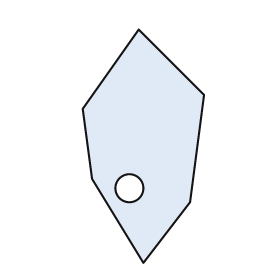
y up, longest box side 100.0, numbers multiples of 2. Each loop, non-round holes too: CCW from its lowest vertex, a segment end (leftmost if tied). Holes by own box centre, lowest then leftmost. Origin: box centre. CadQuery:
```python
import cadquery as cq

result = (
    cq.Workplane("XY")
    .moveTo(0.0, -50.0)
    .lineTo(20.0, -24.0)
    .lineTo(26.0, 22.0)
    .lineTo(-2.0, 50.0)
    .lineTo(-26.0, 16.0)
    .lineTo(-22.0, -14.0)
    .close()
    .moveTo(-6.0, -18.0)
    .circle(6.0)
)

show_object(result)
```